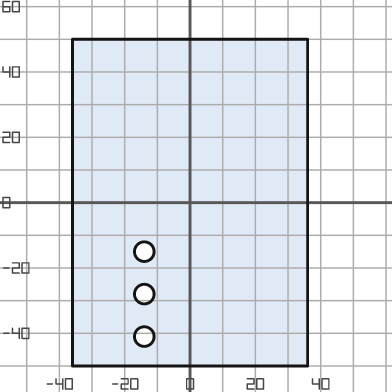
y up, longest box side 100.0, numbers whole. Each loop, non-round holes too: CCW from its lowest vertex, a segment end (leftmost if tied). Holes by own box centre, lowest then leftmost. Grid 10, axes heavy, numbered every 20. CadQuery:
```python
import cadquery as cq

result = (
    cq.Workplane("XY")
    .moveTo(-36.0, -50.0)
    .lineTo(36.0, -50.0)
    .lineTo(36.0, 50.0)
    .lineTo(-36.0, 50.0)
    .close()
    .moveTo(-14.0, -41.0)
    .circle(3.0)
    .moveTo(-14.0, -28.0)
    .circle(3.0)
    .moveTo(-14.0, -15.0)
    .circle(3.0)
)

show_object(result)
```